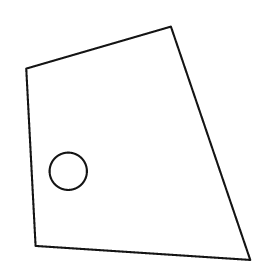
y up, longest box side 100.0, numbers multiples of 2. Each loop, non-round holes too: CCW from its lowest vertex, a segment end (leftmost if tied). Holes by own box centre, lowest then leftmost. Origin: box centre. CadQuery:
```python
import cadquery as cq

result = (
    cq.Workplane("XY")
    .moveTo(48.0, -50.0)
    .lineTo(14.0, 50.0)
    .lineTo(-48.0, 32.0)
    .lineTo(-44.0, -44.0)
    .close()
    .moveTo(-30.0, -12.0)
    .circle(8.0)
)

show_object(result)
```